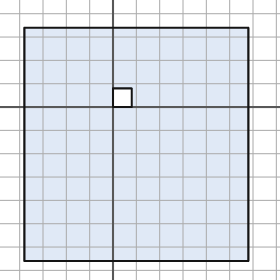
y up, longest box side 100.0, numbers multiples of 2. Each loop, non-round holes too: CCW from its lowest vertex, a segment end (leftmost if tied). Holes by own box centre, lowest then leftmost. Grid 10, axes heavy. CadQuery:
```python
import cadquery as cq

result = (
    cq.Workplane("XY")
    .moveTo(-38.0, -66.0)
    .lineTo(58.0, -66.0)
    .lineTo(58.0, 34.0)
    .lineTo(-38.0, 34.0)
    .close()
    .moveTo(0.0, 0.0)
    .lineTo(8.0, 0.0)
    .lineTo(8.0, 8.0)
    .lineTo(0.0, 8.0)
    .close()
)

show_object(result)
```